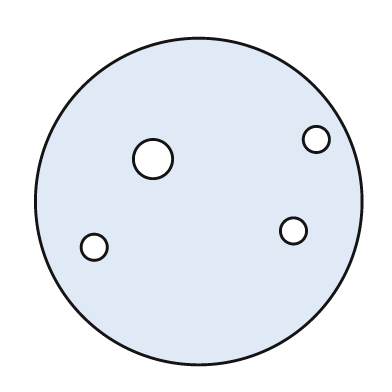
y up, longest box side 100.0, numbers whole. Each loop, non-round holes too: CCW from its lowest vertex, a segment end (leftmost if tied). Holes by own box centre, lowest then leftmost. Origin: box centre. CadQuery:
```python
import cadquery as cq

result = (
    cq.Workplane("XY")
    .moveTo(0.0, 0.0)
    .circle(50.0)
    .moveTo(-32.0, -14.0)
    .circle(4.0)
    .moveTo(29.0, -9.0)
    .circle(4.0)
    .moveTo(-14.0, 13.0)
    .circle(6.0)
    .moveTo(36.0, 19.0)
    .circle(4.0)
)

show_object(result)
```